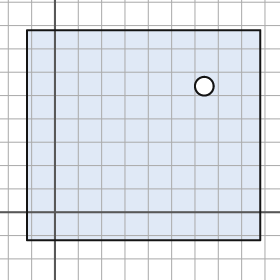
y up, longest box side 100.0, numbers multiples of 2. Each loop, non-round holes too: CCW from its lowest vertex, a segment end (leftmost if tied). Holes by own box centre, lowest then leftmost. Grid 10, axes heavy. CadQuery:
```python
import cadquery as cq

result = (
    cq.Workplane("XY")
    .moveTo(-12.0, -12.0)
    .lineTo(88.0, -12.0)
    .lineTo(88.0, 78.0)
    .lineTo(-12.0, 78.0)
    .close()
    .moveTo(64.0, 54.0)
    .circle(4.0)
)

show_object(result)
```